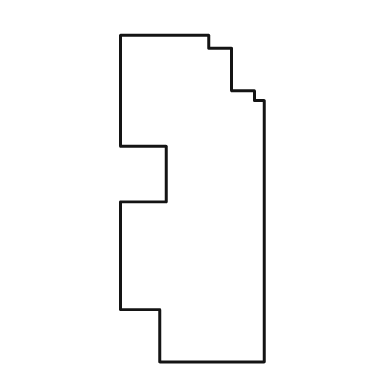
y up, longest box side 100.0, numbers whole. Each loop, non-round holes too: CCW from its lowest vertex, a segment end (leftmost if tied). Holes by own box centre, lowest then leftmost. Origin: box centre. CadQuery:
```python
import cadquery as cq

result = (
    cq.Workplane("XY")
    .moveTo(-10.0, -50.0)
    .lineTo(22.0, -50.0)
    .lineTo(22.0, 30.0)
    .lineTo(19.0, 30.0)
    .lineTo(19.0, 33.0)
    .lineTo(12.0, 33.0)
    .lineTo(12.0, 46.0)
    .lineTo(5.0, 46.0)
    .lineTo(5.0, 50.0)
    .lineTo(-22.0, 50.0)
    .lineTo(-22.0, 16.0)
    .lineTo(-8.0, 16.0)
    .lineTo(-8.0, -1.0)
    .lineTo(-22.0, -1.0)
    .lineTo(-22.0, -34.0)
    .lineTo(-10.0, -34.0)
    .close()
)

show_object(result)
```